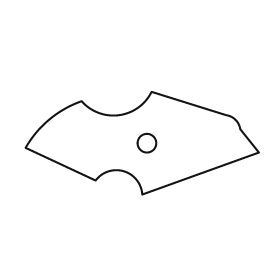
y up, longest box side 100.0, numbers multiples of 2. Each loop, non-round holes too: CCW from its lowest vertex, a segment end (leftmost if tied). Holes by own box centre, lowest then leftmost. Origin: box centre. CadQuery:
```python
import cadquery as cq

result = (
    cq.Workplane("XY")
    .moveTo(0.0, -22.0)
    .lineTo(50.0, -4.0)
    .lineTo(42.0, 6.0)
    .threePointArc((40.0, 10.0), (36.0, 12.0))
    .lineTo(4.0, 22.0)
    .threePointArc((-10.0, 12.0), (-26.0, 18.0))
    .threePointArc((-40.0, 10.0), (-50.0, -2.0))
    .lineTo(-20.0, -16.0)
    .threePointArc((-8.0, -12.0), (0.0, -22.0))
    .close()
    .moveTo(2.0, 0.0)
    .circle(4.0)
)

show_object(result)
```